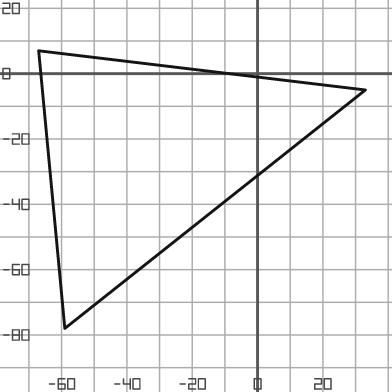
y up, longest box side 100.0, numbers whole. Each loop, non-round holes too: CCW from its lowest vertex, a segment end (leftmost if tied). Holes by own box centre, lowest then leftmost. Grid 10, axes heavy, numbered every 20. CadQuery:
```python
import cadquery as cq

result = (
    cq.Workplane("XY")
    .moveTo(-59.0, -78.0)
    .lineTo(33.0, -5.0)
    .lineTo(-67.0, 7.0)
    .close()
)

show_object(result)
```